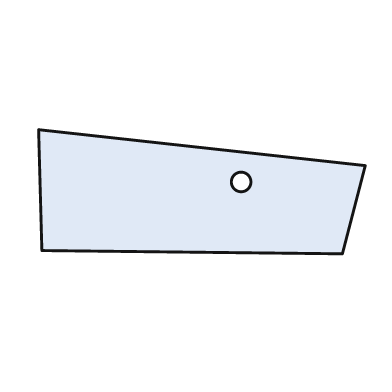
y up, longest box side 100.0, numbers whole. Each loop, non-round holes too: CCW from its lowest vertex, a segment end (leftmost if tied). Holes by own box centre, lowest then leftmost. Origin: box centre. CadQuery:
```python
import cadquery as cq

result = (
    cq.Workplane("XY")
    .moveTo(43.0, -19.0)
    .lineTo(50.0, 8.0)
    .lineTo(-50.0, 19.0)
    .lineTo(-49.0, -18.0)
    .close()
    .moveTo(12.0, 3.0)
    .circle(3.0)
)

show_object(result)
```